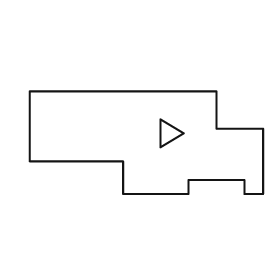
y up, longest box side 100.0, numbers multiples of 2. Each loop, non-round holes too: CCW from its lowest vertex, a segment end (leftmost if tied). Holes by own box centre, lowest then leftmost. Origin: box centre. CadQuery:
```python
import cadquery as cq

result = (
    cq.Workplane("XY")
    .moveTo(-10.0, -22.0)
    .lineTo(18.0, -22.0)
    .lineTo(18.0, -16.0)
    .lineTo(42.0, -16.0)
    .lineTo(42.0, -22.0)
    .lineTo(50.0, -22.0)
    .lineTo(50.0, 6.0)
    .lineTo(30.0, 6.0)
    .lineTo(30.0, 22.0)
    .lineTo(-50.0, 22.0)
    .lineTo(-50.0, -8.0)
    .lineTo(-10.0, -8.0)
    .close()
    .moveTo(6.0, -2.0)
    .lineTo(16.0, 4.0)
    .lineTo(6.0, 10.0)
    .close()
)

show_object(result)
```